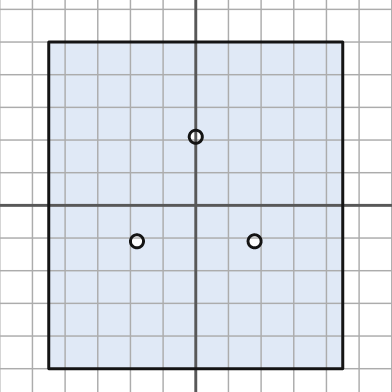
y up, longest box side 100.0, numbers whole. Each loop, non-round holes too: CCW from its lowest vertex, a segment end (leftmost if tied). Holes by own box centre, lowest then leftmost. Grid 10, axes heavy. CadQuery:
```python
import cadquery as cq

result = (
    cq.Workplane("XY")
    .moveTo(-45.0, -50.0)
    .lineTo(45.0, -50.0)
    .lineTo(45.0, 50.0)
    .lineTo(-45.0, 50.0)
    .close()
    .moveTo(-18.0, -11.0)
    .circle(2.0)
    .moveTo(18.0, -11.0)
    .circle(2.0)
    .moveTo(0.0, 21.0)
    .circle(2.0)
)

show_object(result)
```